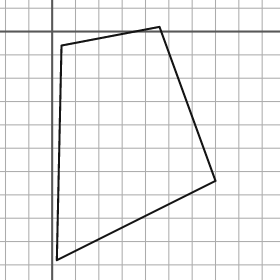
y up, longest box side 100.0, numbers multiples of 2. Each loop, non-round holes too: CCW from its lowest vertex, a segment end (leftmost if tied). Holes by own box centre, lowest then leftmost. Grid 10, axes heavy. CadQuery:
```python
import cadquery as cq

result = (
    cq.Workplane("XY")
    .moveTo(2.0, -98.0)
    .lineTo(70.0, -64.0)
    .lineTo(46.0, 2.0)
    .lineTo(4.0, -6.0)
    .close()
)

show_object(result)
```